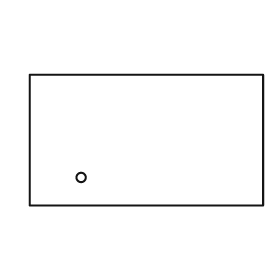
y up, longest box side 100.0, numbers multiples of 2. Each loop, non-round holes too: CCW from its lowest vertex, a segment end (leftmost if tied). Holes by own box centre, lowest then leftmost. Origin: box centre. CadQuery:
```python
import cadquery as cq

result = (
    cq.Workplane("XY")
    .moveTo(-50.0, -28.0)
    .lineTo(50.0, -28.0)
    .lineTo(50.0, 28.0)
    .lineTo(-50.0, 28.0)
    .close()
    .moveTo(-28.0, -16.0)
    .circle(2.0)
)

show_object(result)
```